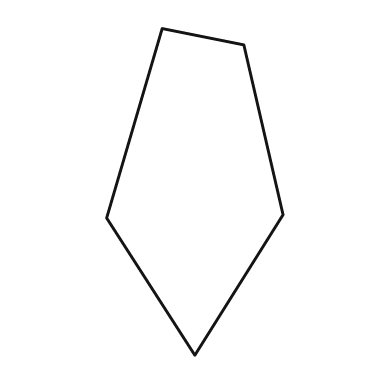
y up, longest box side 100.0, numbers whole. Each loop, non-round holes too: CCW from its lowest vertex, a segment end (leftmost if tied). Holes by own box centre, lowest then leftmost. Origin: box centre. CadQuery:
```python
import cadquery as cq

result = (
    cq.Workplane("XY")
    .moveTo(0.0, -50.0)
    .lineTo(27.0, -7.0)
    .lineTo(15.0, 45.0)
    .lineTo(-10.0, 50.0)
    .lineTo(-27.0, -8.0)
    .close()
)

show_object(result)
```